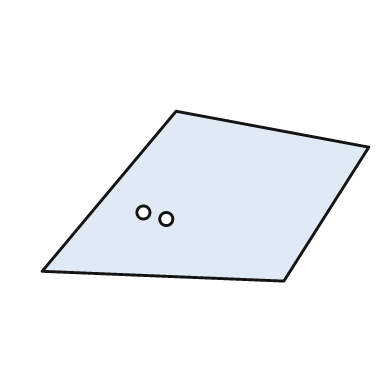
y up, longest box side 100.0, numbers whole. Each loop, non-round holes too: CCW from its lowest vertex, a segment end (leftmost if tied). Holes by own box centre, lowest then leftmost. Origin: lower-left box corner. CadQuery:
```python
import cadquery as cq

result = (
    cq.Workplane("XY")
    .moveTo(74.0, 0.0)
    .lineTo(100.0, 41.0)
    .lineTo(41.0, 52.0)
    .lineTo(0.0, 3.0)
    .close()
    .moveTo(38.0, 19.0)
    .circle(2.0)
    .moveTo(31.0, 21.0)
    .circle(2.0)
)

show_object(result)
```